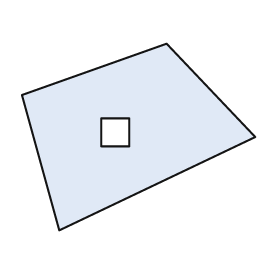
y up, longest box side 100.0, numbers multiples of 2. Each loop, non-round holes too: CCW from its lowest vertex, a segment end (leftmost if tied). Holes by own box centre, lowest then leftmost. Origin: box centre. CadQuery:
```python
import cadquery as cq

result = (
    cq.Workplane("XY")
    .moveTo(-34.0, -40.0)
    .lineTo(50.0, 0.0)
    .lineTo(12.0, 40.0)
    .lineTo(-50.0, 18.0)
    .close()
    .moveTo(-16.0, -4.0)
    .lineTo(-4.0, -4.0)
    .lineTo(-4.0, 8.0)
    .lineTo(-16.0, 8.0)
    .close()
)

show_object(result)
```